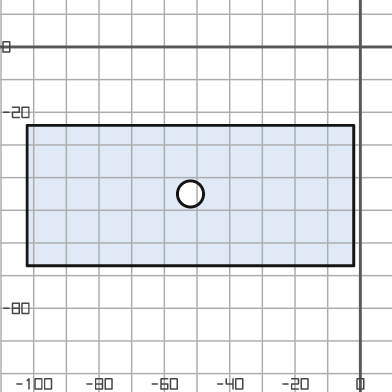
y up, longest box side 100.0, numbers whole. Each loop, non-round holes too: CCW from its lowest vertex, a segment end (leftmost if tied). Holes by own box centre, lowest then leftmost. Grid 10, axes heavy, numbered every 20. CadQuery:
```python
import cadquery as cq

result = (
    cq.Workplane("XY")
    .moveTo(-102.0, -67.0)
    .lineTo(-2.0, -67.0)
    .lineTo(-2.0, -24.0)
    .lineTo(-102.0, -24.0)
    .close()
    .moveTo(-52.0, -45.0)
    .circle(4.0)
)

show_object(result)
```